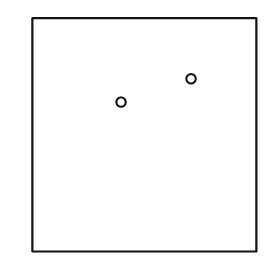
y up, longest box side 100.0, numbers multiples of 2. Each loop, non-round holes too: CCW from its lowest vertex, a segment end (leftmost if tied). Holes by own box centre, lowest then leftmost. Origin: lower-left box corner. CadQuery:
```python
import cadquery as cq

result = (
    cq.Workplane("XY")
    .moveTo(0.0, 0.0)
    .lineTo(96.0, 0.0)
    .lineTo(96.0, 100.0)
    .lineTo(0.0, 100.0)
    .close()
    .moveTo(38.0, 64.0)
    .circle(2.0)
    .moveTo(68.0, 74.0)
    .circle(2.0)
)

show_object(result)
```